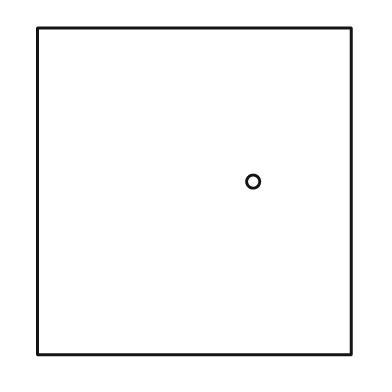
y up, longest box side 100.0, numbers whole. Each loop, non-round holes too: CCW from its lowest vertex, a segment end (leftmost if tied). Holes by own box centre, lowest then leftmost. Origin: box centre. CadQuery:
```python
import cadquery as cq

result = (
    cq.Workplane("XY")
    .moveTo(-48.0, -50.0)
    .lineTo(48.0, -50.0)
    .lineTo(48.0, 50.0)
    .lineTo(-48.0, 50.0)
    .close()
    .moveTo(18.0, 3.0)
    .circle(2.0)
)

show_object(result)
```